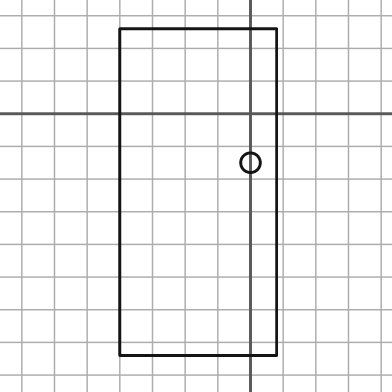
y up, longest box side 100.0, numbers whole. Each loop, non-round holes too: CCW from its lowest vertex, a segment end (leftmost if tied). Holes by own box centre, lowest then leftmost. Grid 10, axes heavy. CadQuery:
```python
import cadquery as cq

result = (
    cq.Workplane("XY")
    .moveTo(-40.0, -74.0)
    .lineTo(8.0, -74.0)
    .lineTo(8.0, 26.0)
    .lineTo(-40.0, 26.0)
    .close()
    .moveTo(0.0, -15.0)
    .circle(3.0)
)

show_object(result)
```